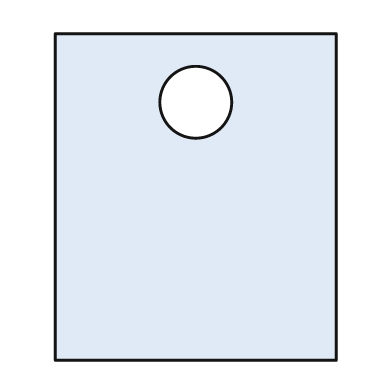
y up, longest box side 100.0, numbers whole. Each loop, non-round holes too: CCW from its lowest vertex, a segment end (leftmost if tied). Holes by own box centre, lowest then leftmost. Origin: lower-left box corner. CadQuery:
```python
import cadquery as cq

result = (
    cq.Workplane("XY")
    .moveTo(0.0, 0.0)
    .lineTo(86.0, 0.0)
    .lineTo(86.0, 100.0)
    .lineTo(0.0, 100.0)
    .close()
    .moveTo(43.0, 79.0)
    .circle(11.0)
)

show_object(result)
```